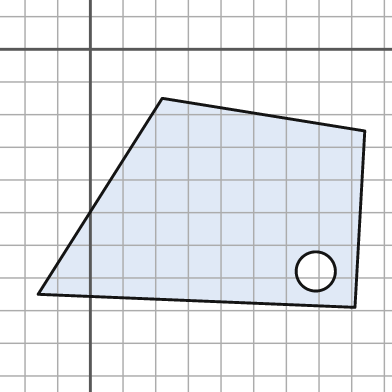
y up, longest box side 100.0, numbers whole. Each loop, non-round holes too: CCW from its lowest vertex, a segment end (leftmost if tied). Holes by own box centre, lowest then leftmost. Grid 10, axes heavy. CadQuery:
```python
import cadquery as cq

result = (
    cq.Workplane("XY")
    .moveTo(81.0, -79.0)
    .lineTo(84.0, -25.0)
    .lineTo(22.0, -15.0)
    .lineTo(-16.0, -75.0)
    .close()
    .moveTo(69.0, -68.0)
    .circle(6.0)
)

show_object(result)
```